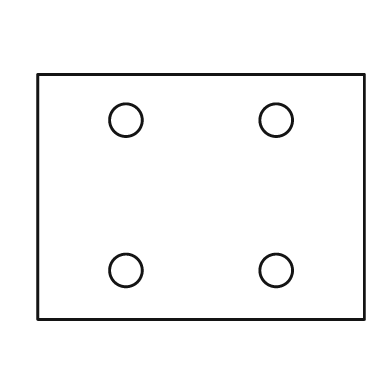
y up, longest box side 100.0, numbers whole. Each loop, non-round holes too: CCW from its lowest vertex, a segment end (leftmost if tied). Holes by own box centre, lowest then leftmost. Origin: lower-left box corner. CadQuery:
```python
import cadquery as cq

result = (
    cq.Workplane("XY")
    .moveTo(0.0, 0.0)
    .lineTo(100.0, 0.0)
    .lineTo(100.0, 75.0)
    .lineTo(0.0, 75.0)
    .close()
    .moveTo(27.0, 15.0)
    .circle(5.0)
    .moveTo(73.0, 15.0)
    .circle(5.0)
    .moveTo(27.0, 61.0)
    .circle(5.0)
    .moveTo(73.0, 61.0)
    .circle(5.0)
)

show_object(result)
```